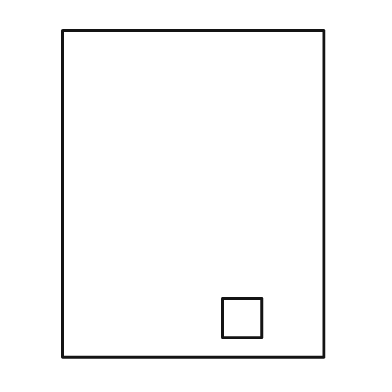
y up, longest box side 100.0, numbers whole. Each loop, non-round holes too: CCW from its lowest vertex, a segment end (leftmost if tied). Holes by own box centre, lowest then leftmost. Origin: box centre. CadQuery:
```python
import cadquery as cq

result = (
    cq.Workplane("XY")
    .moveTo(-40.0, -50.0)
    .lineTo(40.0, -50.0)
    .lineTo(40.0, 50.0)
    .lineTo(-40.0, 50.0)
    .close()
    .moveTo(9.0, -44.0)
    .lineTo(21.0, -44.0)
    .lineTo(21.0, -32.0)
    .lineTo(9.0, -32.0)
    .close()
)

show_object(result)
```